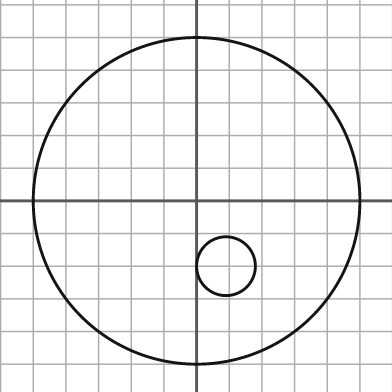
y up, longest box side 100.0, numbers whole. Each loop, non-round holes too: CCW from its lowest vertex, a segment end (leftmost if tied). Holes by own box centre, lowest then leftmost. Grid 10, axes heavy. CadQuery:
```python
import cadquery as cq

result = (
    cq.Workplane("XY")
    .moveTo(0.0, 0.0)
    .circle(50.0)
    .moveTo(9.0, -20.0)
    .circle(9.0)
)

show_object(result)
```